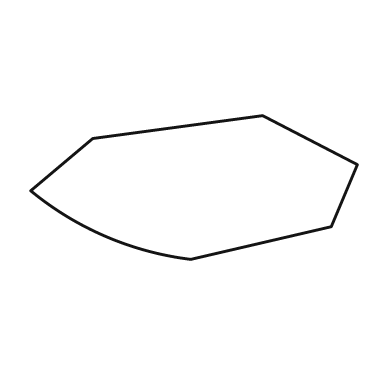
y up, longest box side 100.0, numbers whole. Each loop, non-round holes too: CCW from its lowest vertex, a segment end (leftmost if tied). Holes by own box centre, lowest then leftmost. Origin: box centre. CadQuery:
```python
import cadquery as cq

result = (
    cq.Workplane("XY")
    .moveTo(-1.0, -22.0)
    .lineTo(42.0, -12.0)
    .lineTo(50.0, 7.0)
    .lineTo(21.0, 22.0)
    .lineTo(-31.0, 15.0)
    .lineTo(-50.0, -1.0)
    .threePointArc((-27.0, -15.0), (-1.0, -22.0))
    .close()
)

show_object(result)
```